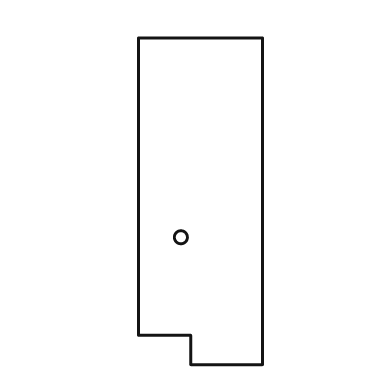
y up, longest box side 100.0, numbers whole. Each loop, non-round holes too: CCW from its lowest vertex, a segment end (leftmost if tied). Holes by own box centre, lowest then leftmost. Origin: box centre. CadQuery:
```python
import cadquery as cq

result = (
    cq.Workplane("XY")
    .moveTo(-3.0, -50.0)
    .lineTo(19.0, -50.0)
    .lineTo(19.0, 50.0)
    .lineTo(-19.0, 50.0)
    .lineTo(-19.0, -41.0)
    .lineTo(-3.0, -41.0)
    .close()
    .moveTo(-6.0, -11.0)
    .circle(2.0)
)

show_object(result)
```